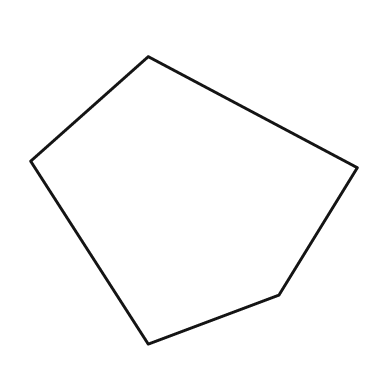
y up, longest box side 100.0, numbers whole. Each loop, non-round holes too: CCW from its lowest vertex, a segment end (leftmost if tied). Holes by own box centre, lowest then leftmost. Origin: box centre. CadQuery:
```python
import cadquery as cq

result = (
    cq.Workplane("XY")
    .moveTo(-14.0, -44.0)
    .lineTo(26.0, -29.0)
    .lineTo(50.0, 10.0)
    .lineTo(-14.0, 44.0)
    .lineTo(-50.0, 12.0)
    .close()
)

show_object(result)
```